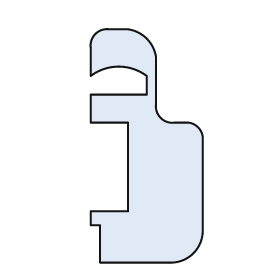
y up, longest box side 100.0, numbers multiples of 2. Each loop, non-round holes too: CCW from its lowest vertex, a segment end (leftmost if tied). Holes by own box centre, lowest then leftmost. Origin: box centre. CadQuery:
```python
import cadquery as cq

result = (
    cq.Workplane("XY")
    .moveTo(-20.0, -50.0)
    .lineTo(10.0, -50.0)
    .threePointArc((20.0, -46.0), (24.0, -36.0))
    .lineTo(24.0, 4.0)
    .threePointArc((22.0, 8.0), (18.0, 10.0))
    .lineTo(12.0, 10.0)
    .threePointArc((6.0, 12.0), (4.0, 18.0))
    .lineTo(4.0, 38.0)
    .threePointArc((0.0, 46.0), (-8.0, 50.0))
    .lineTo(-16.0, 50.0)
    .threePointArc((-22.0, 48.0), (-24.0, 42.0))
    .lineTo(-24.0, 30.0)
    .threePointArc((-12.0, 34.0), (0.0, 30.0))
    .lineTo(0.0, 22.0)
    .lineTo(-24.0, 22.0)
    .lineTo(-24.0, 10.0)
    .lineTo(-8.0, 10.0)
    .lineTo(-8.0, -28.0)
    .lineTo(-24.0, -28.0)
    .lineTo(-24.0, -34.0)
    .lineTo(-20.0, -34.0)
    .close()
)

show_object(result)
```